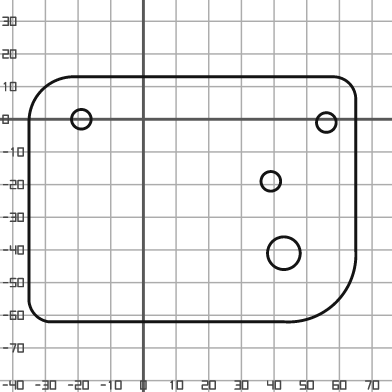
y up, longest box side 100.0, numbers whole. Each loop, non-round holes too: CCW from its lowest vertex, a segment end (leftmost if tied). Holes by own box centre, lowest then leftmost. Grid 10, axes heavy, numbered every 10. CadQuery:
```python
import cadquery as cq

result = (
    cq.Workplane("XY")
    .moveTo(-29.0, -62.0)
    .lineTo(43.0, -62.0)
    .threePointArc((59.0, -56.0), (65.0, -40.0))
    .lineTo(65.0, 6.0)
    .threePointArc((63.0, 11.0), (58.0, 13.0))
    .lineTo(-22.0, 13.0)
    .threePointArc((-31.0, 9.0), (-35.0, 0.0))
    .lineTo(-35.0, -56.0)
    .threePointArc((-33.0, -60.0), (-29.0, -62.0))
    .close()
    .moveTo(43.0, -41.0)
    .circle(5.0)
    .moveTo(39.0, -19.0)
    .circle(3.0)
    .moveTo(56.0, -1.0)
    .circle(3.0)
    .moveTo(-19.0, 0.0)
    .circle(3.0)
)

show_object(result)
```